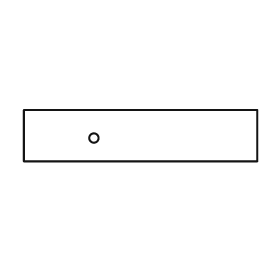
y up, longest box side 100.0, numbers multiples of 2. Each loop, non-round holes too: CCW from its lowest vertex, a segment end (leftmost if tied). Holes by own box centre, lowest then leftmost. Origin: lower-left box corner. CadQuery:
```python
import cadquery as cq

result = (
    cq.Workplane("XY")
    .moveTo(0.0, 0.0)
    .lineTo(100.0, 0.0)
    .lineTo(100.0, 22.0)
    .lineTo(0.0, 22.0)
    .close()
    .moveTo(30.0, 10.0)
    .circle(2.0)
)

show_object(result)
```